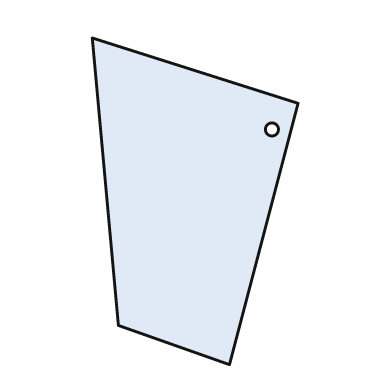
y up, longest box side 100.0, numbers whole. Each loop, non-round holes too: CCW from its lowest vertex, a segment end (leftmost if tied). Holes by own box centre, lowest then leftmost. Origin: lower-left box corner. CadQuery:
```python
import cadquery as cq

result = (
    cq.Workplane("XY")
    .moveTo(42.0, 0.0)
    .lineTo(63.0, 80.0)
    .lineTo(0.0, 100.0)
    .lineTo(8.0, 12.0)
    .close()
    .moveTo(55.0, 72.0)
    .circle(2.0)
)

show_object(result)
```